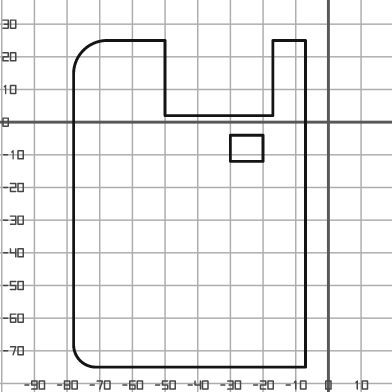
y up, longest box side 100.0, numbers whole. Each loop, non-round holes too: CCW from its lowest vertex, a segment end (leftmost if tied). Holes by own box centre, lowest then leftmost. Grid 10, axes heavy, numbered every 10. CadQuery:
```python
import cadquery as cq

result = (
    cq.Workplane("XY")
    .moveTo(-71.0, -75.0)
    .lineTo(-7.0, -75.0)
    .lineTo(-7.0, 25.0)
    .lineTo(-17.0, 25.0)
    .lineTo(-17.0, 2.0)
    .lineTo(-50.0, 2.0)
    .lineTo(-50.0, 25.0)
    .lineTo(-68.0, 25.0)
    .threePointArc((-75.0, 22.0), (-78.0, 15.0))
    .lineTo(-78.0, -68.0)
    .threePointArc((-76.0, -73.0), (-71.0, -75.0))
    .close()
    .moveTo(-30.0, -12.0)
    .lineTo(-20.0, -12.0)
    .lineTo(-20.0, -4.0)
    .lineTo(-30.0, -4.0)
    .close()
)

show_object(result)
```